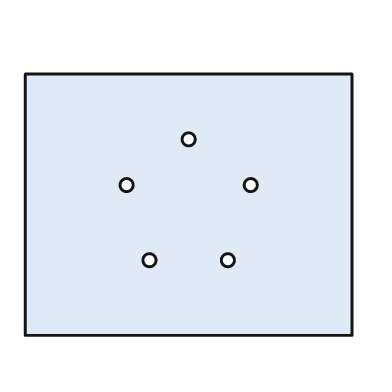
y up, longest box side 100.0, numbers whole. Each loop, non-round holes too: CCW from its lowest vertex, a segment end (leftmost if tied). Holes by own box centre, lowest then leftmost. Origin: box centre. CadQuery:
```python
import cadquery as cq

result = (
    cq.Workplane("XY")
    .moveTo(-50.0, -40.0)
    .lineTo(50.0, -40.0)
    .lineTo(50.0, 40.0)
    .lineTo(-50.0, 40.0)
    .close()
    .moveTo(-12.0, -17.0)
    .circle(2.0)
    .moveTo(12.0, -17.0)
    .circle(2.0)
    .moveTo(-19.0, 6.0)
    .circle(2.0)
    .moveTo(19.0, 6.0)
    .circle(2.0)
    .moveTo(0.0, 20.0)
    .circle(2.0)
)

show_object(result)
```